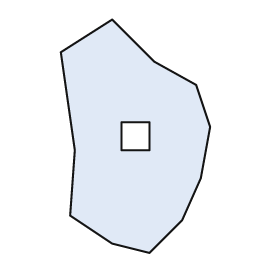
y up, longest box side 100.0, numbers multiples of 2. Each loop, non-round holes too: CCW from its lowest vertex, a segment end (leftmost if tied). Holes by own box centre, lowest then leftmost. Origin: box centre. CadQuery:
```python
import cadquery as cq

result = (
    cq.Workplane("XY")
    .moveTo(6.0, -50.0)
    .lineTo(20.0, -36.0)
    .lineTo(28.0, -18.0)
    .lineTo(32.0, 4.0)
    .lineTo(26.0, 22.0)
    .lineTo(8.0, 32.0)
    .lineTo(-10.0, 50.0)
    .lineTo(-32.0, 36.0)
    .lineTo(-26.0, -6.0)
    .lineTo(-28.0, -34.0)
    .lineTo(-10.0, -46.0)
    .close()
    .moveTo(-6.0, -6.0)
    .lineTo(6.0, -6.0)
    .lineTo(6.0, 6.0)
    .lineTo(-6.0, 6.0)
    .close()
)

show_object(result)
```